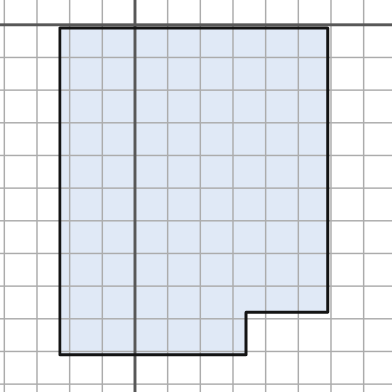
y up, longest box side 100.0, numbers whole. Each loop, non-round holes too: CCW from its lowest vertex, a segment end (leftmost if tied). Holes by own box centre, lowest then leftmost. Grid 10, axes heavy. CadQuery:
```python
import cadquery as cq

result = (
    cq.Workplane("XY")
    .moveTo(-23.0, -101.0)
    .lineTo(34.0, -101.0)
    .lineTo(34.0, -88.0)
    .lineTo(59.0, -88.0)
    .lineTo(59.0, -1.0)
    .lineTo(-23.0, -1.0)
    .close()
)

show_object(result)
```